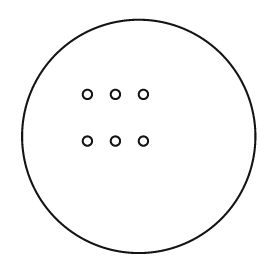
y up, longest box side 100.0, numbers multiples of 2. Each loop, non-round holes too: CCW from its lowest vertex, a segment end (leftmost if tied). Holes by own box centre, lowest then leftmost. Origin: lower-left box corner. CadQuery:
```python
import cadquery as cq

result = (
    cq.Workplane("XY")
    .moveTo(50.0, 50.0)
    .circle(50.0)
    .moveTo(28.0, 48.0)
    .circle(2.0)
    .moveTo(40.0, 48.0)
    .circle(2.0)
    .moveTo(52.0, 48.0)
    .circle(2.0)
    .moveTo(28.0, 68.0)
    .circle(2.0)
    .moveTo(40.0, 68.0)
    .circle(2.0)
    .moveTo(52.0, 68.0)
    .circle(2.0)
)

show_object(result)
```